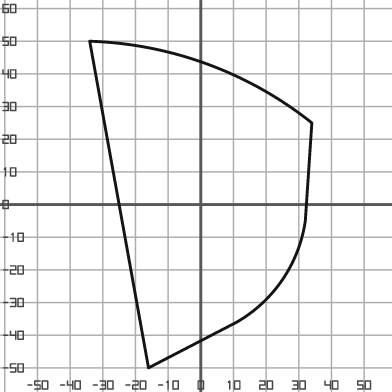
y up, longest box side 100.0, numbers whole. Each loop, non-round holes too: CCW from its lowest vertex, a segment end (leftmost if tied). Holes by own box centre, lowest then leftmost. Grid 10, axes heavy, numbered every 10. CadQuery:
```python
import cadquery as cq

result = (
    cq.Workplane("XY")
    .moveTo(-16.0, -50.0)
    .lineTo(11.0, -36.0)
    .threePointArc((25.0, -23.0), (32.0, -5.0))
    .lineTo(34.0, 25.0)
    .threePointArc((2.0, 43.0), (-34.0, 50.0))
    .close()
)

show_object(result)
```